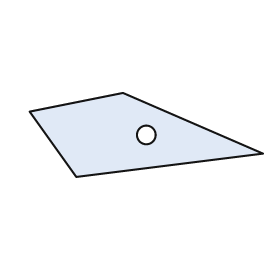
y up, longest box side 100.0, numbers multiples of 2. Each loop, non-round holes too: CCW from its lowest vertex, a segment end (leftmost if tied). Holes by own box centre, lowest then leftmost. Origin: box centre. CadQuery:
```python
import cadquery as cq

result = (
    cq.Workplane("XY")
    .moveTo(-30.0, -18.0)
    .lineTo(50.0, -8.0)
    .lineTo(-10.0, 18.0)
    .lineTo(-50.0, 10.0)
    .close()
    .moveTo(0.0, 0.0)
    .circle(4.0)
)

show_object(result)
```